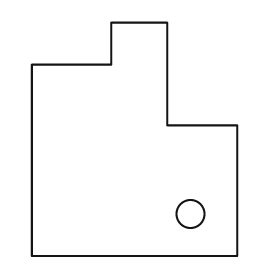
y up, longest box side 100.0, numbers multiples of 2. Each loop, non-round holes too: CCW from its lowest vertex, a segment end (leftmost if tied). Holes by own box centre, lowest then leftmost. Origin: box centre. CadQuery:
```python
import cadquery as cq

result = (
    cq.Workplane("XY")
    .moveTo(-44.0, -50.0)
    .lineTo(44.0, -50.0)
    .lineTo(44.0, 6.0)
    .lineTo(14.0, 6.0)
    .lineTo(14.0, 50.0)
    .lineTo(-10.0, 50.0)
    .lineTo(-10.0, 32.0)
    .lineTo(-44.0, 32.0)
    .close()
    .moveTo(24.0, -32.0)
    .circle(6.0)
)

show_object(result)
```